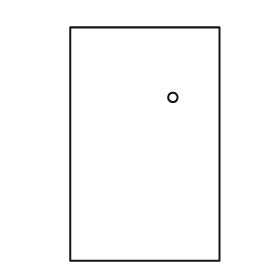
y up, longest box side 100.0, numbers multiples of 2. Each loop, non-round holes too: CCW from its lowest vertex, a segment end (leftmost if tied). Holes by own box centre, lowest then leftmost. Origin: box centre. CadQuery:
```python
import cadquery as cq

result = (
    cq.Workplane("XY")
    .moveTo(-32.0, -50.0)
    .lineTo(32.0, -50.0)
    .lineTo(32.0, 50.0)
    .lineTo(-32.0, 50.0)
    .close()
    .moveTo(12.0, 20.0)
    .circle(2.0)
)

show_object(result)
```